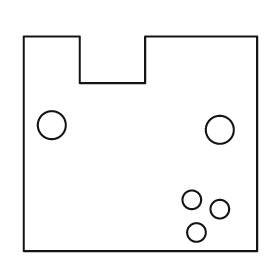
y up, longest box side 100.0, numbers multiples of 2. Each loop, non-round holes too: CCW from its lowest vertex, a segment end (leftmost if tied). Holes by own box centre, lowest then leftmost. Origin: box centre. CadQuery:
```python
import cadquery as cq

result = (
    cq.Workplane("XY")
    .moveTo(-50.0, -46.0)
    .lineTo(50.0, -46.0)
    .lineTo(50.0, 46.0)
    .lineTo(2.0, 46.0)
    .lineTo(2.0, 26.0)
    .lineTo(-26.0, 26.0)
    .lineTo(-26.0, 46.0)
    .lineTo(-50.0, 46.0)
    .close()
    .moveTo(24.0, -38.0)
    .circle(4.0)
    .moveTo(34.0, -28.0)
    .circle(4.0)
    .moveTo(22.0, -24.0)
    .circle(4.0)
    .moveTo(34.0, 6.0)
    .circle(6.0)
    .moveTo(-38.0, 8.0)
    .circle(6.0)
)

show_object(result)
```